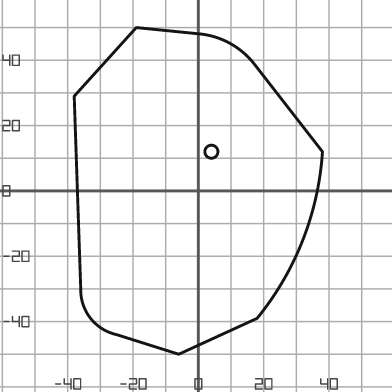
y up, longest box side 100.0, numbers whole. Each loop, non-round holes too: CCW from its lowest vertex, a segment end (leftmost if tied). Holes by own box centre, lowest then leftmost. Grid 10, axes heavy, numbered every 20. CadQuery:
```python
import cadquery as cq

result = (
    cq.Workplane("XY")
    .moveTo(-6.0, -50.0)
    .lineTo(18.0, -39.0)
    .threePointArc((32.0, -15.0), (38.0, 12.0))
    .lineTo(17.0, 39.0)
    .threePointArc((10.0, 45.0), (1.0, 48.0))
    .lineTo(-19.0, 50.0)
    .lineTo(-38.0, 29.0)
    .lineTo(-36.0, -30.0)
    .threePointArc((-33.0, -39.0), (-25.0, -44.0))
    .close()
    .moveTo(4.0, 12.0)
    .circle(2.0)
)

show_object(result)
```